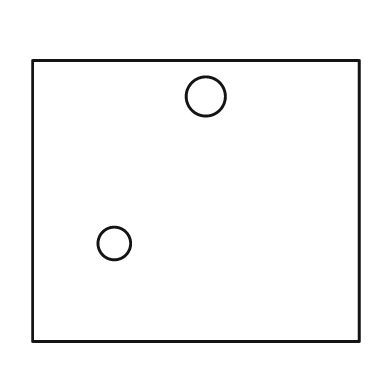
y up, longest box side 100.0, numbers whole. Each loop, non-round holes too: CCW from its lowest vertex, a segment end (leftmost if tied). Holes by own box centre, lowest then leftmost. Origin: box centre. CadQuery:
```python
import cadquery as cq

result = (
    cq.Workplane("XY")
    .moveTo(-50.0, -43.0)
    .lineTo(50.0, -43.0)
    .lineTo(50.0, 43.0)
    .lineTo(-50.0, 43.0)
    .close()
    .moveTo(-25.0, -13.0)
    .circle(5.0)
    .moveTo(3.0, 32.0)
    .circle(6.0)
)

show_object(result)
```